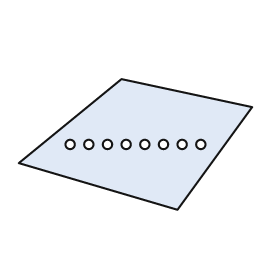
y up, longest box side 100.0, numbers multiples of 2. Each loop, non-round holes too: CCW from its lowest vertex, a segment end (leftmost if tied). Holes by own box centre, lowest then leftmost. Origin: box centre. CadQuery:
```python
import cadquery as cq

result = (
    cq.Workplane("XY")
    .moveTo(18.0, -28.0)
    .lineTo(50.0, 16.0)
    .lineTo(-6.0, 28.0)
    .lineTo(-50.0, -8.0)
    .close()
    .moveTo(-28.0, 0.0)
    .circle(2.0)
    .moveTo(-20.0, 0.0)
    .circle(2.0)
    .moveTo(-12.0, 0.0)
    .circle(2.0)
    .moveTo(-4.0, 0.0)
    .circle(2.0)
    .moveTo(4.0, 0.0)
    .circle(2.0)
    .moveTo(12.0, 0.0)
    .circle(2.0)
    .moveTo(20.0, 0.0)
    .circle(2.0)
    .moveTo(28.0, 0.0)
    .circle(2.0)
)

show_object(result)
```